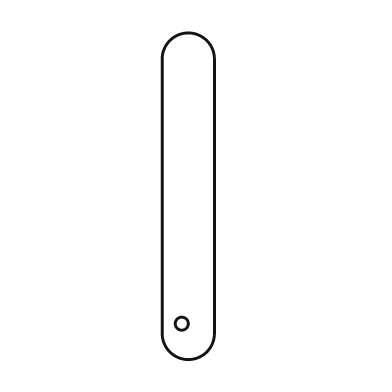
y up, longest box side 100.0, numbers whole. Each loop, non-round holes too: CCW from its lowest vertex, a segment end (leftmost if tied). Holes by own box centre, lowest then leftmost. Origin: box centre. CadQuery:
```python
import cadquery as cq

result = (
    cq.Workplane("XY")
    .moveTo(-8.0, -42.0)
    .threePointArc((0.0, -50.0), (8.0, -42.0))
    .lineTo(8.0, 42.0)
    .threePointArc((0.0, 50.0), (-8.0, 42.0))
    .close()
    .moveTo(-2.0, -39.0)
    .circle(2.0)
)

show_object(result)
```